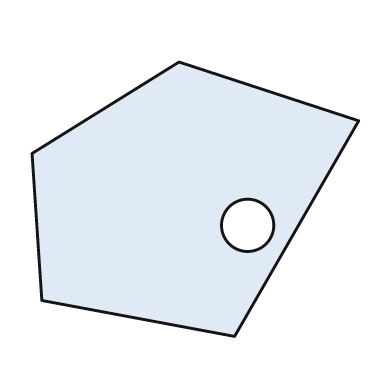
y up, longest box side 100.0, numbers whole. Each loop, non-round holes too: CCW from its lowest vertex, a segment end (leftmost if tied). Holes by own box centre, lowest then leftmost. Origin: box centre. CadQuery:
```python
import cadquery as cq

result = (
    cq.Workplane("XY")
    .moveTo(12.0, -42.0)
    .lineTo(50.0, 24.0)
    .lineTo(-5.0, 42.0)
    .lineTo(-50.0, 14.0)
    .lineTo(-47.0, -31.0)
    .close()
    .moveTo(16.0, -8.0)
    .circle(8.0)
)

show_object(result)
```